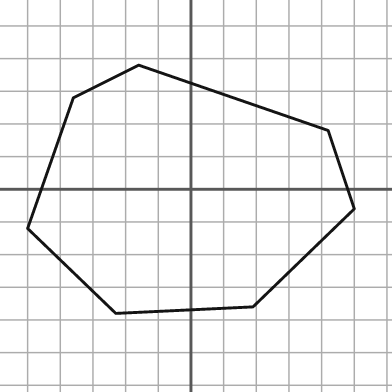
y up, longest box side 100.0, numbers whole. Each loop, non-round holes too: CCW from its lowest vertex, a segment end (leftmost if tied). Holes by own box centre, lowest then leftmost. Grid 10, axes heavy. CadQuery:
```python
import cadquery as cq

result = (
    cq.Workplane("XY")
    .moveTo(-23.0, -38.0)
    .lineTo(19.0, -36.0)
    .lineTo(50.0, -6.0)
    .lineTo(42.0, 18.0)
    .lineTo(-16.0, 38.0)
    .lineTo(-36.0, 28.0)
    .lineTo(-50.0, -12.0)
    .close()
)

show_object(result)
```